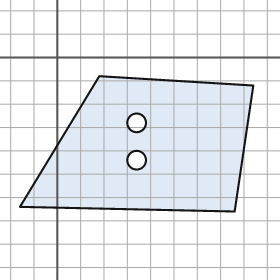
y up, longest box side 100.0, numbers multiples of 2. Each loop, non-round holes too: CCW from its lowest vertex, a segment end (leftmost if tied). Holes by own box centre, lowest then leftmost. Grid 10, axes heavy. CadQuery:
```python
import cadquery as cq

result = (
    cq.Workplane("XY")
    .moveTo(76.0, -66.0)
    .lineTo(84.0, -12.0)
    .lineTo(18.0, -8.0)
    .lineTo(-16.0, -64.0)
    .close()
    .moveTo(34.0, -44.0)
    .circle(4.0)
    .moveTo(34.0, -28.0)
    .circle(4.0)
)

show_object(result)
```